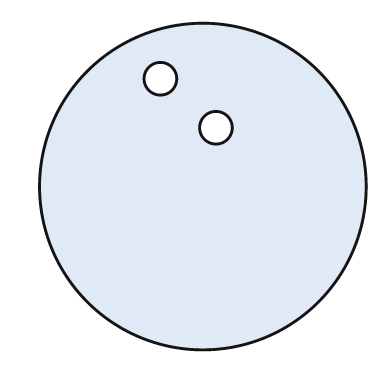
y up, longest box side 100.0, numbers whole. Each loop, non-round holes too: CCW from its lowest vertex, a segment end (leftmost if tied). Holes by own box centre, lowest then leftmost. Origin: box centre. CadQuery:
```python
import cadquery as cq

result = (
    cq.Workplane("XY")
    .moveTo(0.0, 0.0)
    .circle(50.0)
    .moveTo(4.0, 18.0)
    .circle(5.0)
    .moveTo(-13.0, 33.0)
    .circle(5.0)
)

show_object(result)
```